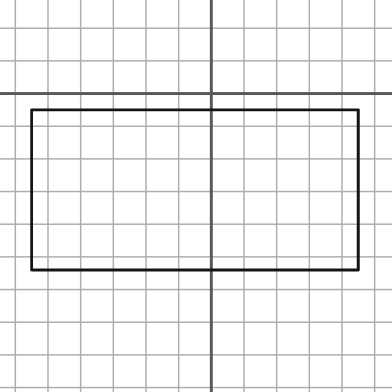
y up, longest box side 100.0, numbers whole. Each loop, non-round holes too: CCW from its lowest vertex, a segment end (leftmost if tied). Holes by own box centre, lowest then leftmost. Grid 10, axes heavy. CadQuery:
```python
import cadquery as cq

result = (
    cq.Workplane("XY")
    .moveTo(-55.0, -54.0)
    .lineTo(45.0, -54.0)
    .lineTo(45.0, -5.0)
    .lineTo(-55.0, -5.0)
    .close()
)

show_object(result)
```